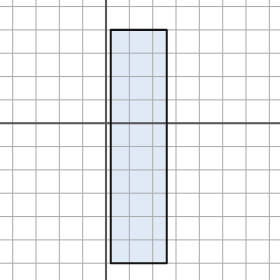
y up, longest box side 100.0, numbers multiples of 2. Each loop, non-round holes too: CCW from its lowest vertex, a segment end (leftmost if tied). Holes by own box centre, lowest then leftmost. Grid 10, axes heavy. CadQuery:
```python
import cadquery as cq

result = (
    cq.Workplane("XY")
    .moveTo(2.0, -60.0)
    .lineTo(26.0, -60.0)
    .lineTo(26.0, 40.0)
    .lineTo(2.0, 40.0)
    .close()
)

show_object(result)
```